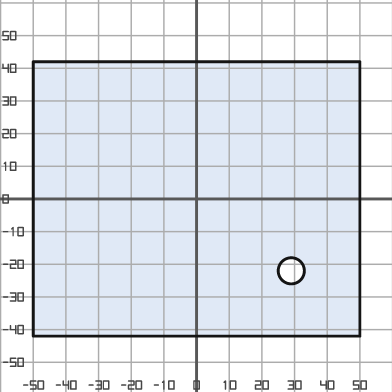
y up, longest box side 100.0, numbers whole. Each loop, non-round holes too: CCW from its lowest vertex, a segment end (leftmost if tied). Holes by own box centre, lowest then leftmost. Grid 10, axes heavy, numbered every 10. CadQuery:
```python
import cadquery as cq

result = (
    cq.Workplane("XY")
    .moveTo(-50.0, -42.0)
    .lineTo(50.0, -42.0)
    .lineTo(50.0, 42.0)
    .lineTo(-50.0, 42.0)
    .close()
    .moveTo(29.0, -22.0)
    .circle(4.0)
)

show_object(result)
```